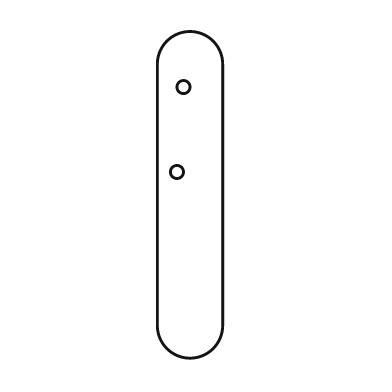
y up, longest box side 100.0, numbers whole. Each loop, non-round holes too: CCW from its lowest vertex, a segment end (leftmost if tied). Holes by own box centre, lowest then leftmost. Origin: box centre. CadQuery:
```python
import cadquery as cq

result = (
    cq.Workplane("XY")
    .moveTo(-10.0, -40.0)
    .threePointArc((0.0, -50.0), (10.0, -40.0))
    .lineTo(10.0, 40.0)
    .threePointArc((0.0, 50.0), (-10.0, 40.0))
    .close()
    .moveTo(-4.0, 7.0)
    .circle(2.0)
    .moveTo(-2.0, 33.0)
    .circle(2.0)
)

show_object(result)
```